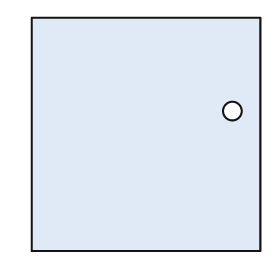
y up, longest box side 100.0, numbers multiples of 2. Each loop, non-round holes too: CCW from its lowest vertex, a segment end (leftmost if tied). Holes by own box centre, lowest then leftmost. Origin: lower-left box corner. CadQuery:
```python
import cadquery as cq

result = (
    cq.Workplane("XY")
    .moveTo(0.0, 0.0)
    .lineTo(98.0, 0.0)
    .lineTo(98.0, 100.0)
    .lineTo(0.0, 100.0)
    .close()
    .moveTo(86.0, 60.0)
    .circle(4.0)
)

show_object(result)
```